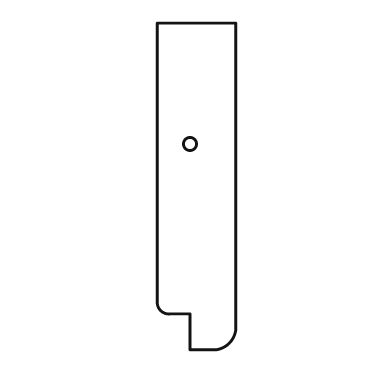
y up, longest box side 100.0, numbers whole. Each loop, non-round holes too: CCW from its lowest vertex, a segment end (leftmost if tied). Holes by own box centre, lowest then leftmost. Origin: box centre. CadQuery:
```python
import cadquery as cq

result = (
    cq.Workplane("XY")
    .moveTo(-2.0, -50.0)
    .lineTo(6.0, -50.0)
    .threePointArc((10.0, -48.0), (12.0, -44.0))
    .lineTo(12.0, 50.0)
    .lineTo(-12.0, 50.0)
    .lineTo(-12.0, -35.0)
    .threePointArc((-11.0, -38.0), (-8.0, -39.0))
    .lineTo(-2.0, -39.0)
    .close()
    .moveTo(-2.0, 13.0)
    .circle(2.0)
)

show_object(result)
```